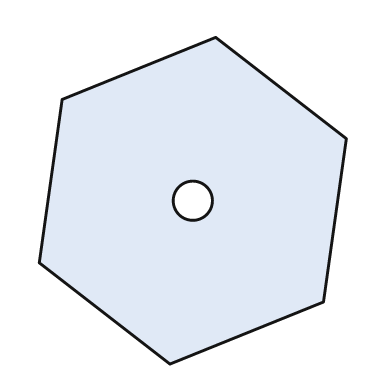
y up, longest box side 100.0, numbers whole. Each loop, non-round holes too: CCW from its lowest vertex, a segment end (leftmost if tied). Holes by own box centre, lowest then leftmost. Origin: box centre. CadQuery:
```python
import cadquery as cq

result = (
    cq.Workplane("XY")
    .moveTo(-7.0, -50.0)
    .lineTo(40.0, -31.0)
    .lineTo(47.0, 19.0)
    .lineTo(7.0, 50.0)
    .lineTo(-40.0, 31.0)
    .lineTo(-47.0, -19.0)
    .close()
    .moveTo(0.0, 0.0)
    .circle(6.0)
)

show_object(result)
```